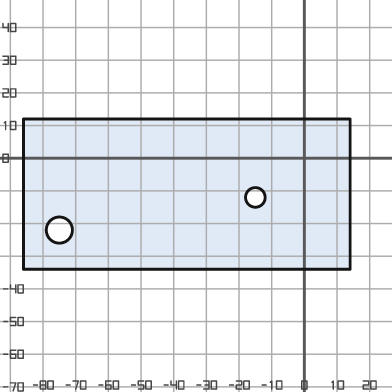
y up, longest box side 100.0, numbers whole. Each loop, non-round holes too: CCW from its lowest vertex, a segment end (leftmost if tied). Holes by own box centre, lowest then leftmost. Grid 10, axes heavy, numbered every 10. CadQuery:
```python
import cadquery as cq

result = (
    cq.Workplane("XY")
    .moveTo(-86.0, -34.0)
    .lineTo(14.0, -34.0)
    .lineTo(14.0, 12.0)
    .lineTo(-86.0, 12.0)
    .close()
    .moveTo(-75.0, -22.0)
    .circle(4.0)
    .moveTo(-15.0, -12.0)
    .circle(3.0)
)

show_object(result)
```